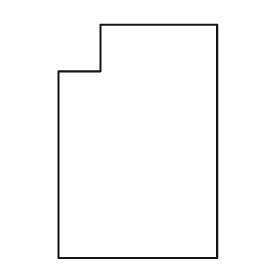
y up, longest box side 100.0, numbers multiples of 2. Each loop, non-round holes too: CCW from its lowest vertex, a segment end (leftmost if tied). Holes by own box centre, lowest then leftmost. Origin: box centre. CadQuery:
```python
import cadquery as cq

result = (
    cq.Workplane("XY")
    .moveTo(-34.0, -50.0)
    .lineTo(34.0, -50.0)
    .lineTo(34.0, 50.0)
    .lineTo(-16.0, 50.0)
    .lineTo(-16.0, 30.0)
    .lineTo(-34.0, 30.0)
    .close()
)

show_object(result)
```